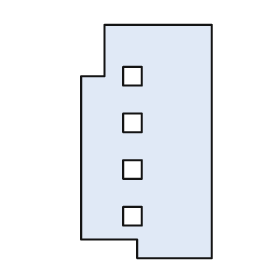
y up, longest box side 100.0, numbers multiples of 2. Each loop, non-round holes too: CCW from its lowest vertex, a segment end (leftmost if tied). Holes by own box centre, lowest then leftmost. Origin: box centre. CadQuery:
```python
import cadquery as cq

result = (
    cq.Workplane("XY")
    .moveTo(-4.0, -50.0)
    .lineTo(28.0, -50.0)
    .lineTo(28.0, 50.0)
    .lineTo(-18.0, 50.0)
    .lineTo(-18.0, 28.0)
    .lineTo(-28.0, 28.0)
    .lineTo(-28.0, -42.0)
    .lineTo(-4.0, -42.0)
    .close()
    .moveTo(-10.0, -36.0)
    .lineTo(-2.0, -36.0)
    .lineTo(-2.0, -28.0)
    .lineTo(-10.0, -28.0)
    .close()
    .moveTo(-10.0, -16.0)
    .lineTo(-2.0, -16.0)
    .lineTo(-2.0, -8.0)
    .lineTo(-10.0, -8.0)
    .close()
    .moveTo(-10.0, 4.0)
    .lineTo(-2.0, 4.0)
    .lineTo(-2.0, 12.0)
    .lineTo(-10.0, 12.0)
    .close()
    .moveTo(-10.0, 24.0)
    .lineTo(-2.0, 24.0)
    .lineTo(-2.0, 32.0)
    .lineTo(-10.0, 32.0)
    .close()
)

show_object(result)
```